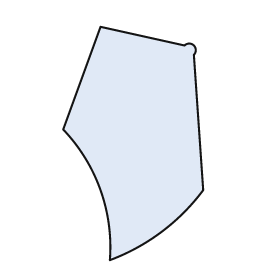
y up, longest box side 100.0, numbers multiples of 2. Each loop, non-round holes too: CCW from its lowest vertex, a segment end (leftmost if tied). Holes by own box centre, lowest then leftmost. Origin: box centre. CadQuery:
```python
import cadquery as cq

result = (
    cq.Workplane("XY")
    .moveTo(-10.0, -50.0)
    .threePointArc((12.0, -38.0), (30.0, -20.0))
    .lineTo(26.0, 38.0)
    .threePointArc((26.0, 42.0), (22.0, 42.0))
    .lineTo(-14.0, 50.0)
    .lineTo(-30.0, 6.0)
    .threePointArc((-14.0, -20.0), (-10.0, -50.0))
    .close()
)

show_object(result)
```